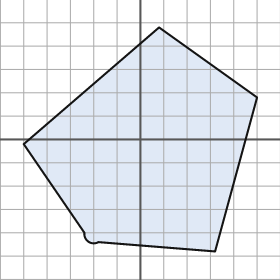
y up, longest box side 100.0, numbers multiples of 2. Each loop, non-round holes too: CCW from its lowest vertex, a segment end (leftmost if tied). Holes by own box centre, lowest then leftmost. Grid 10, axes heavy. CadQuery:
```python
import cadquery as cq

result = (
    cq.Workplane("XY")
    .moveTo(32.0, -48.0)
    .lineTo(50.0, 18.0)
    .lineTo(8.0, 48.0)
    .lineTo(-50.0, -2.0)
    .lineTo(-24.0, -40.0)
    .threePointArc((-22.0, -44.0), (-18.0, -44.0))
    .close()
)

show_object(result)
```